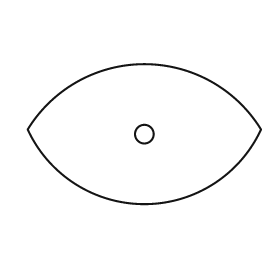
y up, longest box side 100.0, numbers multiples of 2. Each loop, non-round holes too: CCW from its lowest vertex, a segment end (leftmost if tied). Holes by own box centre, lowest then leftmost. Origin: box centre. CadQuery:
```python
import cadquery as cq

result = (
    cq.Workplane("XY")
    .moveTo(-50.0, 2.0)
    .threePointArc((0.0, -30.0), (50.0, 2.0))
    .threePointArc((0.0, 30.0), (-50.0, 2.0))
    .close()
    .moveTo(0.0, 0.0)
    .circle(4.0)
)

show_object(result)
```